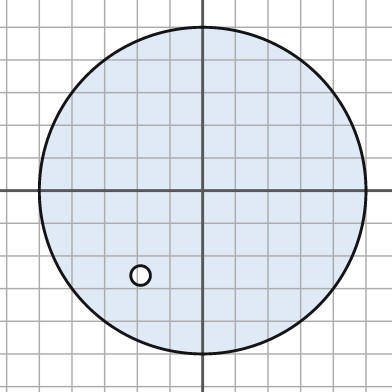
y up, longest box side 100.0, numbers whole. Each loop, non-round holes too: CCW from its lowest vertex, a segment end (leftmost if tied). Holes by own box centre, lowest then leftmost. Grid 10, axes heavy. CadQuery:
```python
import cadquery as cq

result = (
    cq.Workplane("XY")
    .moveTo(0.0, 0.0)
    .circle(50.0)
    .moveTo(-19.0, -26.0)
    .circle(3.0)
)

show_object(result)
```